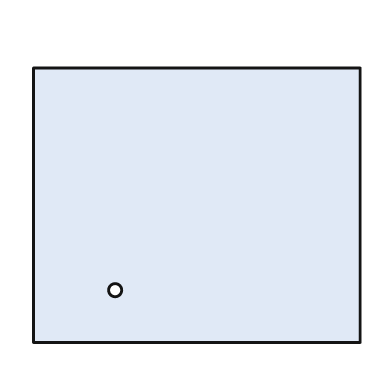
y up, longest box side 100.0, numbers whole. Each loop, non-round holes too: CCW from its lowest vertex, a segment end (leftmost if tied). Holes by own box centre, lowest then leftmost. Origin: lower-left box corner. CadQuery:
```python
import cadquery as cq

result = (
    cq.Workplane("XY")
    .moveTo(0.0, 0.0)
    .lineTo(100.0, 0.0)
    .lineTo(100.0, 84.0)
    .lineTo(0.0, 84.0)
    .close()
    .moveTo(25.0, 16.0)
    .circle(2.0)
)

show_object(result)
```